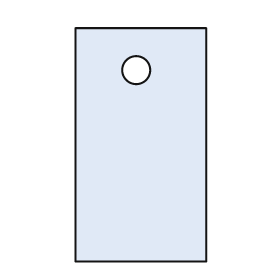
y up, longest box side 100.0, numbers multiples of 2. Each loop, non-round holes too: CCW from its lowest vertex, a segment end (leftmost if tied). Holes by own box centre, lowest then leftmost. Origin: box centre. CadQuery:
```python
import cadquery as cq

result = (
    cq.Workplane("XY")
    .moveTo(-28.0, -50.0)
    .lineTo(28.0, -50.0)
    .lineTo(28.0, 50.0)
    .lineTo(-28.0, 50.0)
    .close()
    .moveTo(-2.0, 32.0)
    .circle(6.0)
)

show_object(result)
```